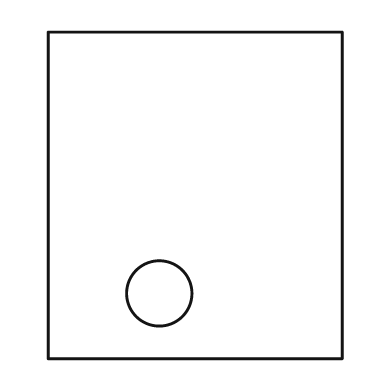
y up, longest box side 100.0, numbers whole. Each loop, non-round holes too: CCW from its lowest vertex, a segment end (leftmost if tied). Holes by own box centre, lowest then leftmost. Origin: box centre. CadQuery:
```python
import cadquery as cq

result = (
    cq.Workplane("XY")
    .moveTo(-45.0, -50.0)
    .lineTo(45.0, -50.0)
    .lineTo(45.0, 50.0)
    .lineTo(-45.0, 50.0)
    .close()
    .moveTo(-11.0, -30.0)
    .circle(10.0)
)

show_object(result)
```